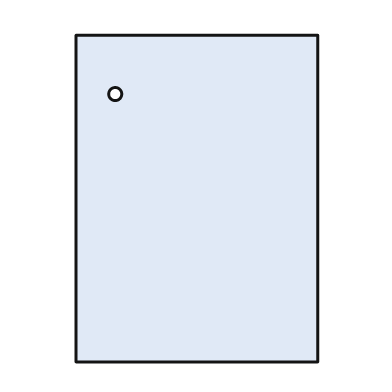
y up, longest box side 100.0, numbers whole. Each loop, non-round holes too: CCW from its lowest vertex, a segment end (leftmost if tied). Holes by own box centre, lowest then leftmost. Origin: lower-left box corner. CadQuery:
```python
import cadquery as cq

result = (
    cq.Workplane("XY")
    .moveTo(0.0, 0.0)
    .lineTo(74.0, 0.0)
    .lineTo(74.0, 100.0)
    .lineTo(0.0, 100.0)
    .close()
    .moveTo(12.0, 82.0)
    .circle(2.0)
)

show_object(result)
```